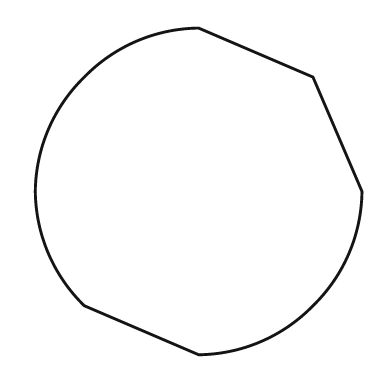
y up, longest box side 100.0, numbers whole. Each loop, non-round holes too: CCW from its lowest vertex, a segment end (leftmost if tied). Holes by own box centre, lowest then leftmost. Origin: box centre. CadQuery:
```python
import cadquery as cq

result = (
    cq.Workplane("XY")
    .moveTo(0.0, -50.0)
    .threePointArc((19.0, -46.0), (35.0, -35.0))
    .threePointArc((46.0, -19.0), (50.0, 0.0))
    .lineTo(35.0, 35.0)
    .lineTo(0.0, 50.0)
    .threePointArc((-19.0, 46.0), (-35.0, 35.0))
    .threePointArc((-46.0, 19.0), (-50.0, 0.0))
    .threePointArc((-46.0, -19.0), (-35.0, -35.0))
    .close()
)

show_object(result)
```